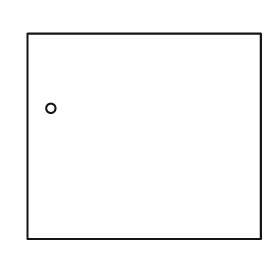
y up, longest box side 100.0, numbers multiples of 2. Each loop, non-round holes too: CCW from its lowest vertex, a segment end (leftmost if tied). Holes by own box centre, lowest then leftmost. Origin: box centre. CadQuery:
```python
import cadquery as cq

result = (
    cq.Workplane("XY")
    .moveTo(-50.0, -44.0)
    .lineTo(50.0, -44.0)
    .lineTo(50.0, 44.0)
    .lineTo(-50.0, 44.0)
    .close()
    .moveTo(-40.0, 12.0)
    .circle(2.0)
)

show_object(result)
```